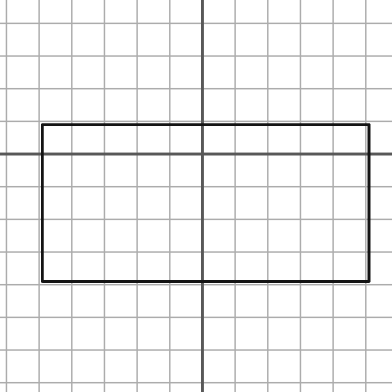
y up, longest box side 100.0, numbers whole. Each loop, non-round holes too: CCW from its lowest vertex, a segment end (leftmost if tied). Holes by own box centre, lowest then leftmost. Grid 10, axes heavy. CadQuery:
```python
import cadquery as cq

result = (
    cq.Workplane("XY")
    .moveTo(-49.0, -39.0)
    .lineTo(51.0, -39.0)
    .lineTo(51.0, 9.0)
    .lineTo(-49.0, 9.0)
    .close()
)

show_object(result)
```